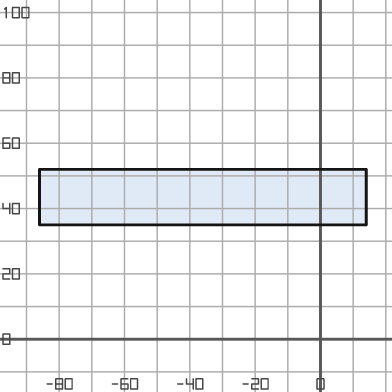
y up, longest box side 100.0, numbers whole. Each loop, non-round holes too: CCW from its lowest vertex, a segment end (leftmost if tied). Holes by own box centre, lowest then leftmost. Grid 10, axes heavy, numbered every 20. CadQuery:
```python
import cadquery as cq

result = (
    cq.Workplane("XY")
    .moveTo(-86.0, 35.0)
    .lineTo(14.0, 35.0)
    .lineTo(14.0, 52.0)
    .lineTo(-86.0, 52.0)
    .close()
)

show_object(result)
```